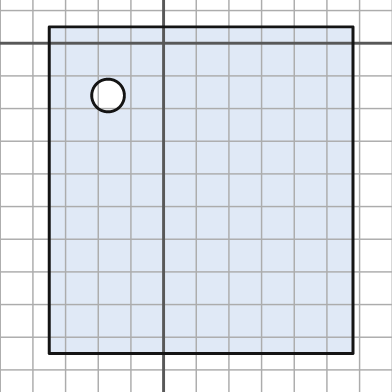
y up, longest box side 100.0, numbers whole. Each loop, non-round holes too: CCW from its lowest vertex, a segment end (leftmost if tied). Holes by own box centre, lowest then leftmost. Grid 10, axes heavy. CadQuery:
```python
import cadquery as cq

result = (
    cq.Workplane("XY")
    .moveTo(-35.0, -95.0)
    .lineTo(58.0, -95.0)
    .lineTo(58.0, 5.0)
    .lineTo(-35.0, 5.0)
    .close()
    .moveTo(-17.0, -16.0)
    .circle(5.0)
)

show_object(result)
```